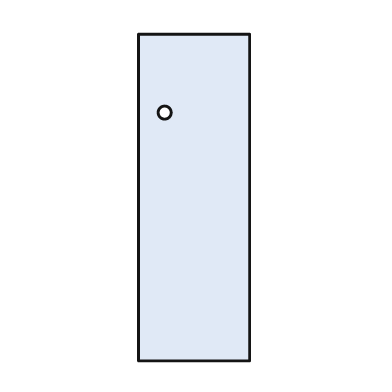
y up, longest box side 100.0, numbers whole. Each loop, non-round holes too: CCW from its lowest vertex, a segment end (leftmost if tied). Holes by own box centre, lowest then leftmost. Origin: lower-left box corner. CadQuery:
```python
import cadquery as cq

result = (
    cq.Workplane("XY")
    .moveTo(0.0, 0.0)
    .lineTo(34.0, 0.0)
    .lineTo(34.0, 100.0)
    .lineTo(0.0, 100.0)
    .close()
    .moveTo(8.0, 76.0)
    .circle(2.0)
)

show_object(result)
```